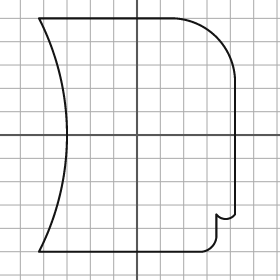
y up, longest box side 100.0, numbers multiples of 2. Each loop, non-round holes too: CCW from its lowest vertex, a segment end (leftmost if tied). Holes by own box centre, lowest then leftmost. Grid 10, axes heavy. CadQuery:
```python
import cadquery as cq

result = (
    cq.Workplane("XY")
    .moveTo(-42.0, -50.0)
    .lineTo(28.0, -50.0)
    .threePointArc((32.0, -48.0), (34.0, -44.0))
    .lineTo(34.0, -34.0)
    .threePointArc((38.0, -36.0), (42.0, -34.0))
    .lineTo(42.0, 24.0)
    .threePointArc((34.0, 42.0), (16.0, 50.0))
    .lineTo(-42.0, 50.0)
    .threePointArc((-30.0, 0.0), (-42.0, -50.0))
    .close()
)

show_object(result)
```